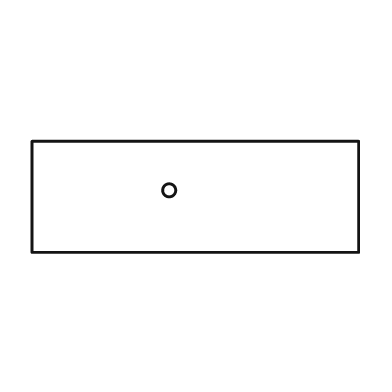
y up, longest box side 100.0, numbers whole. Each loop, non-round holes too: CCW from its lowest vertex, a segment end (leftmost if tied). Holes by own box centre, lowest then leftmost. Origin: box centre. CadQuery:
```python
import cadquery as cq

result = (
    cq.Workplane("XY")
    .moveTo(-50.0, -17.0)
    .lineTo(50.0, -17.0)
    .lineTo(50.0, 17.0)
    .lineTo(-50.0, 17.0)
    .close()
    .moveTo(-8.0, 2.0)
    .circle(2.0)
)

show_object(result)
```